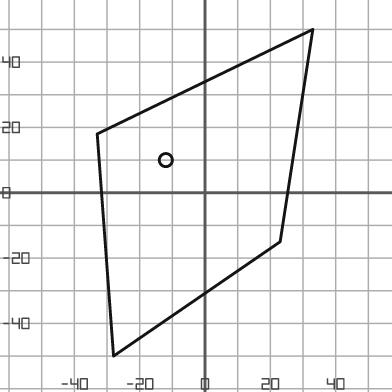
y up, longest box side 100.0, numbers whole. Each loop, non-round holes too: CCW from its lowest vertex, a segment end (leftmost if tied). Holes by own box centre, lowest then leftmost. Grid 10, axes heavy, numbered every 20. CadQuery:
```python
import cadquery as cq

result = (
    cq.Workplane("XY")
    .moveTo(-28.0, -50.0)
    .lineTo(23.0, -15.0)
    .lineTo(33.0, 50.0)
    .lineTo(-33.0, 18.0)
    .close()
    .moveTo(-12.0, 10.0)
    .circle(2.0)
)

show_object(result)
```